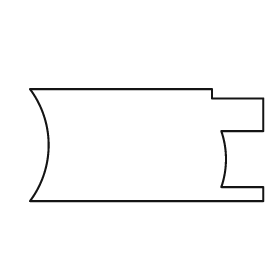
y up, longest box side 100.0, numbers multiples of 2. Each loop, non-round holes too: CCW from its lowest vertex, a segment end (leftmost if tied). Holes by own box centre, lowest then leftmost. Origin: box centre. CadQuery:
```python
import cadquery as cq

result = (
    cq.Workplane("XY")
    .moveTo(-50.0, -24.0)
    .lineTo(50.0, -24.0)
    .lineTo(50.0, -18.0)
    .lineTo(32.0, -18.0)
    .threePointArc((34.0, -6.0), (32.0, 6.0))
    .lineTo(50.0, 6.0)
    .lineTo(50.0, 20.0)
    .lineTo(28.0, 20.0)
    .lineTo(28.0, 24.0)
    .lineTo(-50.0, 24.0)
    .threePointArc((-42.0, 0.0), (-50.0, -24.0))
    .close()
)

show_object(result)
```